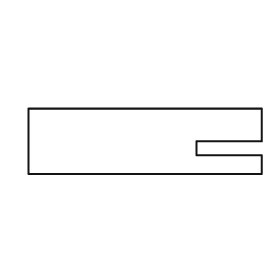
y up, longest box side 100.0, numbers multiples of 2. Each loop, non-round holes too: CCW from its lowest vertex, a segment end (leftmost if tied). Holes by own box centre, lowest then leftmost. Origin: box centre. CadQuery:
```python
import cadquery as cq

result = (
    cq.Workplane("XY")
    .moveTo(-50.0, -14.0)
    .lineTo(50.0, -14.0)
    .lineTo(50.0, -6.0)
    .lineTo(22.0, -6.0)
    .lineTo(22.0, 0.0)
    .lineTo(50.0, 0.0)
    .lineTo(50.0, 14.0)
    .lineTo(-50.0, 14.0)
    .close()
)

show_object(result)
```